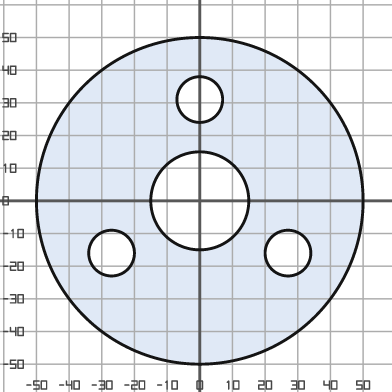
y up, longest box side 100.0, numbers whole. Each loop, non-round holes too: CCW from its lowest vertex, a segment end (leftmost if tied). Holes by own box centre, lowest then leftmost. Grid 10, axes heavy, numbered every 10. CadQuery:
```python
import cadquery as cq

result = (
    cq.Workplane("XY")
    .moveTo(0.0, 0.0)
    .circle(50.0)
    .moveTo(-27.0, -16.0)
    .circle(7.0)
    .moveTo(27.0, -16.0)
    .circle(7.0)
    .moveTo(0.0, 0.0)
    .circle(15.0)
    .moveTo(0.0, 31.0)
    .circle(7.0)
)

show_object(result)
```